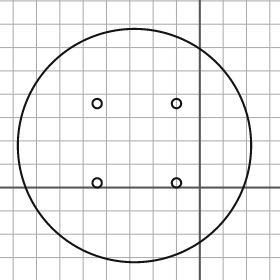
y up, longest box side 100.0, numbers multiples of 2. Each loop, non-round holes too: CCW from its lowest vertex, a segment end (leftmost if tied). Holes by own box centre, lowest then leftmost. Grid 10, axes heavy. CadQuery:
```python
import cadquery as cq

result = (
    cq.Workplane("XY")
    .moveTo(-28.0, 18.0)
    .circle(50.0)
    .moveTo(-44.0, 2.0)
    .circle(2.0)
    .moveTo(-10.0, 2.0)
    .circle(2.0)
    .moveTo(-44.0, 36.0)
    .circle(2.0)
    .moveTo(-10.0, 36.0)
    .circle(2.0)
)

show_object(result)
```